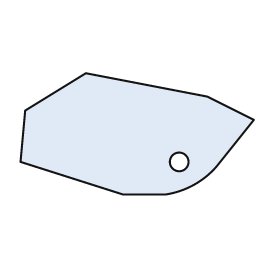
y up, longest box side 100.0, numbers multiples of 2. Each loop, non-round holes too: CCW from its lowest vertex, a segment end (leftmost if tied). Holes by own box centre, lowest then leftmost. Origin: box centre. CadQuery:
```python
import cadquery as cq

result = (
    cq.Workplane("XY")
    .moveTo(-6.0, -26.0)
    .lineTo(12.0, -26.0)
    .threePointArc((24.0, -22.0), (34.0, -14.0))
    .lineTo(50.0, 6.0)
    .lineTo(30.0, 16.0)
    .lineTo(-22.0, 26.0)
    .lineTo(-48.0, 10.0)
    .lineTo(-50.0, -12.0)
    .close()
    .moveTo(18.0, -12.0)
    .circle(4.0)
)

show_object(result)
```